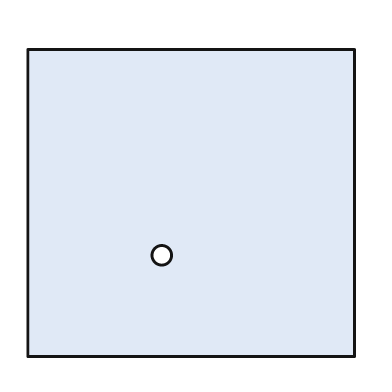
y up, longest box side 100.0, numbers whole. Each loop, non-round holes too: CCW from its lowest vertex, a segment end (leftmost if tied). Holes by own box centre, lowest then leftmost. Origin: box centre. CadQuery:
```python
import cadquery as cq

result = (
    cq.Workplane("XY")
    .moveTo(-50.0, -47.0)
    .lineTo(50.0, -47.0)
    .lineTo(50.0, 47.0)
    .lineTo(-50.0, 47.0)
    .close()
    .moveTo(-9.0, -16.0)
    .circle(3.0)
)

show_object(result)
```